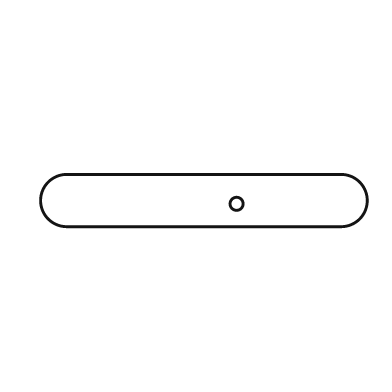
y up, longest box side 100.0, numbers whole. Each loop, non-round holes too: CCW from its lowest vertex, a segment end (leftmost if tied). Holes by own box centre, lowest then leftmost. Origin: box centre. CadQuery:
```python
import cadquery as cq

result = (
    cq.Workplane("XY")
    .moveTo(-42.0, -8.0)
    .lineTo(42.0, -8.0)
    .threePointArc((50.0, 0.0), (42.0, 8.0))
    .lineTo(-42.0, 8.0)
    .threePointArc((-50.0, 0.0), (-42.0, -8.0))
    .close()
    .moveTo(10.0, -1.0)
    .circle(2.0)
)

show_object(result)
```